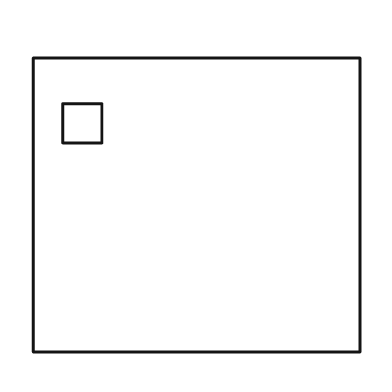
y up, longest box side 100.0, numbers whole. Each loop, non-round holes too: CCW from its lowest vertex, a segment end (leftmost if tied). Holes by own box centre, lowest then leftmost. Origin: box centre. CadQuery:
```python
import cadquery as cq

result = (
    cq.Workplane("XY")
    .moveTo(-50.0, -45.0)
    .lineTo(50.0, -45.0)
    .lineTo(50.0, 45.0)
    .lineTo(-50.0, 45.0)
    .close()
    .moveTo(-41.0, 19.0)
    .lineTo(-29.0, 19.0)
    .lineTo(-29.0, 31.0)
    .lineTo(-41.0, 31.0)
    .close()
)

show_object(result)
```